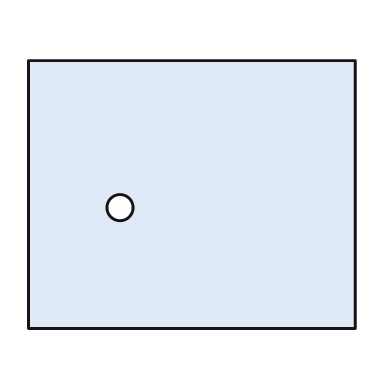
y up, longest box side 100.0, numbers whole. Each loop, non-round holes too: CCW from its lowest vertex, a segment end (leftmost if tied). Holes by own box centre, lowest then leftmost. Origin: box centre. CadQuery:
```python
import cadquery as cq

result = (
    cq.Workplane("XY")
    .moveTo(-50.0, -41.0)
    .lineTo(50.0, -41.0)
    .lineTo(50.0, 41.0)
    .lineTo(-50.0, 41.0)
    .close()
    .moveTo(-22.0, -4.0)
    .circle(4.0)
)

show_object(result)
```